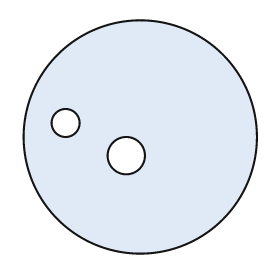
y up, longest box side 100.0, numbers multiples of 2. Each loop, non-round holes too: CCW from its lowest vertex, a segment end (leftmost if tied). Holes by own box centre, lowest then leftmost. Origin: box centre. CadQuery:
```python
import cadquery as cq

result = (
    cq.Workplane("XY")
    .moveTo(0.0, 0.0)
    .circle(50.0)
    .moveTo(-6.0, -8.0)
    .circle(8.0)
    .moveTo(-32.0, 6.0)
    .circle(6.0)
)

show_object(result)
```